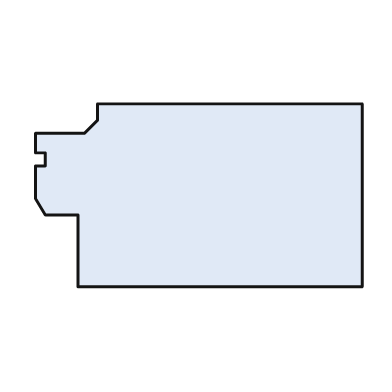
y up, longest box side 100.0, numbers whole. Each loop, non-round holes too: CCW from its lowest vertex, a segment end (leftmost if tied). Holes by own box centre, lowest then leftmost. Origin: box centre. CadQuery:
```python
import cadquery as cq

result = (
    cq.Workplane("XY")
    .moveTo(-37.0, -28.0)
    .lineTo(50.0, -28.0)
    .lineTo(50.0, 28.0)
    .lineTo(-31.0, 28.0)
    .lineTo(-31.0, 23.0)
    .lineTo(-35.0, 19.0)
    .lineTo(-50.0, 19.0)
    .lineTo(-50.0, 13.0)
    .lineTo(-47.0, 13.0)
    .lineTo(-47.0, 9.0)
    .lineTo(-50.0, 9.0)
    .lineTo(-50.0, -1.0)
    .lineTo(-47.0, -6.0)
    .lineTo(-37.0, -6.0)
    .close()
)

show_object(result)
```